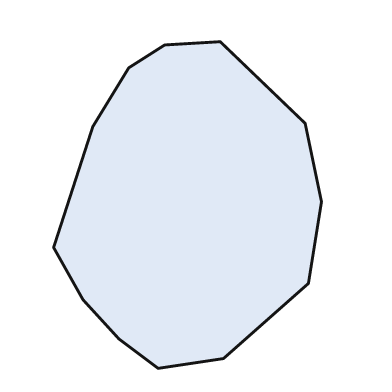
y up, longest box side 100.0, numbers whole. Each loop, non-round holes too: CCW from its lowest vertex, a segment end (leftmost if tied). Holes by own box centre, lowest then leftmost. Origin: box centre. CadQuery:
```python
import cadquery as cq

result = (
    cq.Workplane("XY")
    .moveTo(-9.0, -50.0)
    .lineTo(11.0, -47.0)
    .lineTo(37.0, -24.0)
    .lineTo(41.0, 1.0)
    .lineTo(36.0, 25.0)
    .lineTo(10.0, 50.0)
    .lineTo(-7.0, 49.0)
    .lineTo(-18.0, 42.0)
    .lineTo(-29.0, 24.0)
    .lineTo(-41.0, -13.0)
    .lineTo(-32.0, -29.0)
    .lineTo(-21.0, -41.0)
    .close()
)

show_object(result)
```